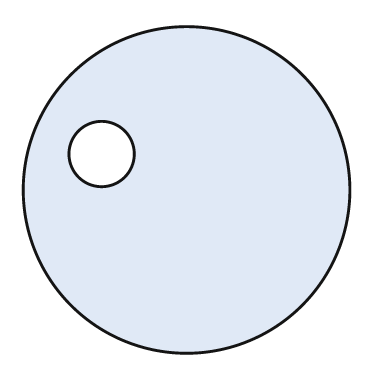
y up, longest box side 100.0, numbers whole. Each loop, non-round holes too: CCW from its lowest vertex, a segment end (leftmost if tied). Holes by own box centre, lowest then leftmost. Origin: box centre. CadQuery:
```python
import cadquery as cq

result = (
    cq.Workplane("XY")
    .moveTo(0.0, 0.0)
    .circle(50.0)
    .moveTo(-26.0, 11.0)
    .circle(10.0)
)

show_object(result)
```